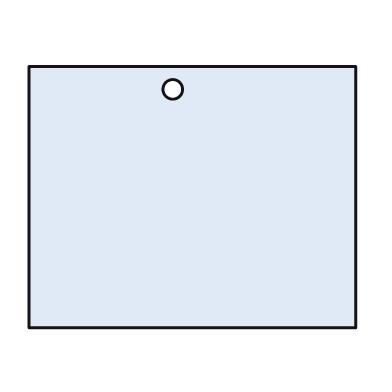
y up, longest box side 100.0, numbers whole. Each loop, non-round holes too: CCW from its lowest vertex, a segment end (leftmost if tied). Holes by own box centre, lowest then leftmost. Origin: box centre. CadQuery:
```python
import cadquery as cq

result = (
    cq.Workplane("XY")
    .moveTo(-50.0, -40.0)
    .lineTo(50.0, -40.0)
    .lineTo(50.0, 40.0)
    .lineTo(-50.0, 40.0)
    .close()
    .moveTo(-6.0, 33.0)
    .circle(3.0)
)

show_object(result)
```